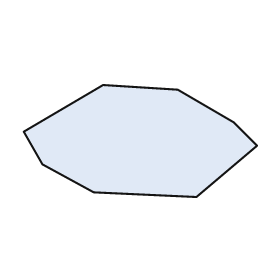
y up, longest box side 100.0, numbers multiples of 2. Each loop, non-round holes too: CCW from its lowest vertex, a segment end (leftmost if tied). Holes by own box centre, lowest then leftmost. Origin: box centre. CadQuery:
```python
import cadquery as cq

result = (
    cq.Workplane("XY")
    .moveTo(24.0, -24.0)
    .lineTo(50.0, -2.0)
    .lineTo(40.0, 8.0)
    .lineTo(16.0, 22.0)
    .lineTo(-16.0, 24.0)
    .lineTo(-50.0, 4.0)
    .lineTo(-42.0, -10.0)
    .lineTo(-20.0, -22.0)
    .close()
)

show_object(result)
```